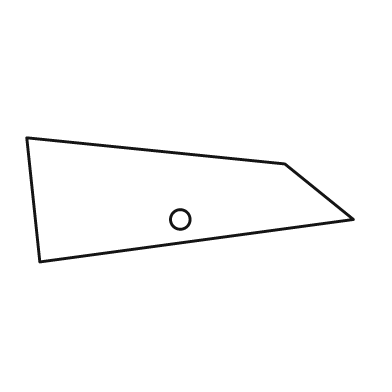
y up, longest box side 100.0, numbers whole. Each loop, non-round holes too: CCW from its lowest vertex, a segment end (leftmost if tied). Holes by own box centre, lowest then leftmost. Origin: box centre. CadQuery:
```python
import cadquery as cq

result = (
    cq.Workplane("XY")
    .moveTo(-46.0, -19.0)
    .lineTo(50.0, -6.0)
    .lineTo(29.0, 11.0)
    .lineTo(-50.0, 19.0)
    .close()
    .moveTo(-3.0, -6.0)
    .circle(3.0)
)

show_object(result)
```